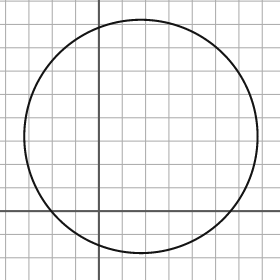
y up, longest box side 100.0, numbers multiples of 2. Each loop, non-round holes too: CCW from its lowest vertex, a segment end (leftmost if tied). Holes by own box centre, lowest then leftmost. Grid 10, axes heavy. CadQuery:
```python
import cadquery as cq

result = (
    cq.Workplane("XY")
    .moveTo(18.0, 32.0)
    .circle(50.0)
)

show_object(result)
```